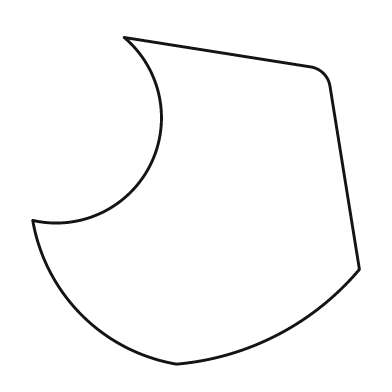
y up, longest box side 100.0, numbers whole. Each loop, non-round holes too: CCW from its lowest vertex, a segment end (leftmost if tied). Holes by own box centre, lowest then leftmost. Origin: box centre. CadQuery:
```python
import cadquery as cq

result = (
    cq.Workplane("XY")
    .moveTo(-6.0, -50.0)
    .threePointArc((25.0, -41.0), (50.0, -21.0))
    .lineTo(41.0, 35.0)
    .threePointArc((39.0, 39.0), (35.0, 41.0))
    .lineTo(-22.0, 50.0)
    .threePointArc((-14.0, 11.0), (-50.0, -6.0))
    .threePointArc((-35.0, -35.0), (-6.0, -50.0))
    .close()
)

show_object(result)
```